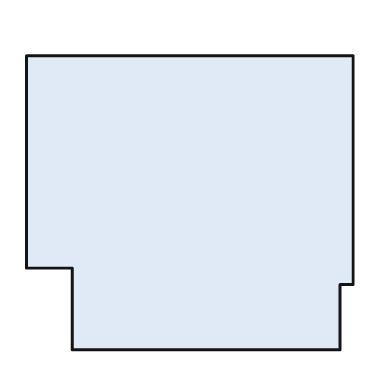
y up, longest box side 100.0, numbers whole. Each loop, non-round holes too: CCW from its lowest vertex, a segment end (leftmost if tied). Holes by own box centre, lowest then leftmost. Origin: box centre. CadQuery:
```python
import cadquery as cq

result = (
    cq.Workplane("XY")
    .moveTo(-36.0, -45.0)
    .lineTo(46.0, -45.0)
    .lineTo(46.0, -25.0)
    .lineTo(50.0, -25.0)
    .lineTo(50.0, 45.0)
    .lineTo(-50.0, 45.0)
    .lineTo(-50.0, -20.0)
    .lineTo(-36.0, -20.0)
    .close()
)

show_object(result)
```